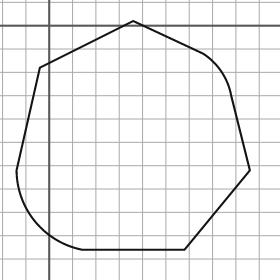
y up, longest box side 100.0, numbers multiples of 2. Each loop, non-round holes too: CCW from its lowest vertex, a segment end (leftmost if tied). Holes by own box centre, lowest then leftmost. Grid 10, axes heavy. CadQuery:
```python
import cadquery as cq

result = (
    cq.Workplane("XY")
    .moveTo(14.0, -96.0)
    .lineTo(58.0, -96.0)
    .lineTo(86.0, -62.0)
    .lineTo(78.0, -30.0)
    .threePointArc((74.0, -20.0), (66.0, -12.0))
    .lineTo(36.0, 2.0)
    .lineTo(-4.0, -18.0)
    .lineTo(-14.0, -62.0)
    .threePointArc((-6.0, -84.0), (14.0, -96.0))
    .close()
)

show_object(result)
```